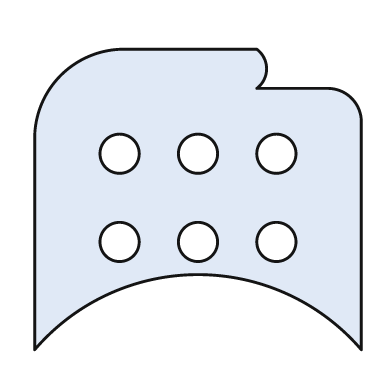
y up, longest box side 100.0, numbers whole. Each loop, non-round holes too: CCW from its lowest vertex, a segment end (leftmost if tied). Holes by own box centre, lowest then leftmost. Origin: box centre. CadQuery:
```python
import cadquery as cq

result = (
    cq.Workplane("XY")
    .moveTo(-50.0, -46.0)
    .threePointArc((0.0, -23.0), (50.0, -46.0))
    .lineTo(50.0, 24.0)
    .threePointArc((47.0, 31.0), (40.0, 34.0))
    .lineTo(18.0, 34.0)
    .threePointArc((21.0, 40.0), (18.0, 46.0))
    .lineTo(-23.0, 46.0)
    .threePointArc((-42.0, 38.0), (-50.0, 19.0))
    .close()
    .moveTo(-24.0, -13.0)
    .circle(6.0)
    .moveTo(0.0, -13.0)
    .circle(6.0)
    .moveTo(24.0, -13.0)
    .circle(6.0)
    .moveTo(-24.0, 14.0)
    .circle(6.0)
    .moveTo(0.0, 14.0)
    .circle(6.0)
    .moveTo(24.0, 14.0)
    .circle(6.0)
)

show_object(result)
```